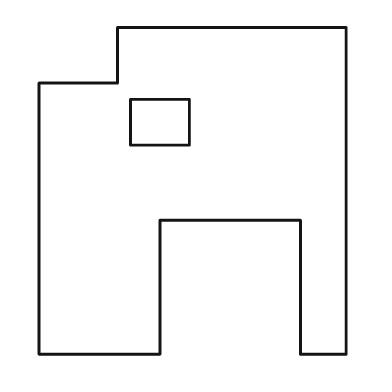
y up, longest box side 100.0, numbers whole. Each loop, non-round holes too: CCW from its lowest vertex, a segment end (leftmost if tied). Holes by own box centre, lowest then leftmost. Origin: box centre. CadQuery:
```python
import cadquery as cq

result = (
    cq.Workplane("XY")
    .moveTo(-47.0, -50.0)
    .lineTo(-10.0, -50.0)
    .lineTo(-10.0, -9.0)
    .lineTo(33.0, -9.0)
    .lineTo(33.0, -50.0)
    .lineTo(47.0, -50.0)
    .lineTo(47.0, 50.0)
    .lineTo(-23.0, 50.0)
    .lineTo(-23.0, 33.0)
    .lineTo(-47.0, 33.0)
    .close()
    .moveTo(-19.0, 14.0)
    .lineTo(-1.0, 14.0)
    .lineTo(-1.0, 28.0)
    .lineTo(-19.0, 28.0)
    .close()
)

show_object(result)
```